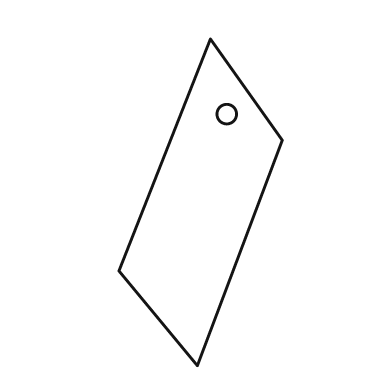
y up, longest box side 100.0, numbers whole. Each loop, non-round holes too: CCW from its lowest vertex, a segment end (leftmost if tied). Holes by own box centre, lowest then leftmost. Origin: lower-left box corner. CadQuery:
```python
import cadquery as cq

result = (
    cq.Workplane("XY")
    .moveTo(24.0, 0.0)
    .lineTo(50.0, 69.0)
    .lineTo(28.0, 100.0)
    .lineTo(0.0, 29.0)
    .close()
    .moveTo(33.0, 77.0)
    .circle(3.0)
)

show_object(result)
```